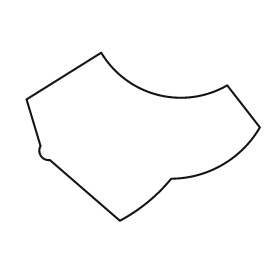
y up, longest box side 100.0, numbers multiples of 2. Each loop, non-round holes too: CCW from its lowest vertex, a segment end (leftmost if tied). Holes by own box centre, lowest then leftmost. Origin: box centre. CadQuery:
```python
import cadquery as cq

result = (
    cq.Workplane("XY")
    .moveTo(-10.0, -36.0)
    .threePointArc((2.0, -28.0), (12.0, -18.0))
    .threePointArc((34.0, -12.0), (50.0, 4.0))
    .lineTo(36.0, 22.0)
    .threePointArc((6.0, 18.0), (-18.0, 36.0))
    .lineTo(-50.0, 16.0)
    .lineTo(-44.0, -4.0)
    .threePointArc((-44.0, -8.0), (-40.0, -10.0))
    .close()
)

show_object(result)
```